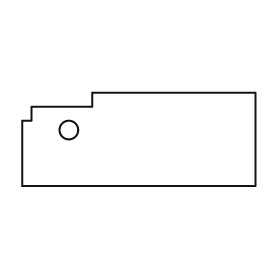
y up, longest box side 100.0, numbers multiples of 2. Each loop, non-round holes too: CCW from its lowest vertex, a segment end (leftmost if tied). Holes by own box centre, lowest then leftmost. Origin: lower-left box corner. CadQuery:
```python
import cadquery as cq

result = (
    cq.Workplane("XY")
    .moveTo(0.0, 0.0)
    .lineTo(100.0, 0.0)
    .lineTo(100.0, 40.0)
    .lineTo(30.0, 40.0)
    .lineTo(30.0, 34.0)
    .lineTo(4.0, 34.0)
    .lineTo(4.0, 28.0)
    .lineTo(0.0, 28.0)
    .close()
    .moveTo(20.0, 24.0)
    .circle(4.0)
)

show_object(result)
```